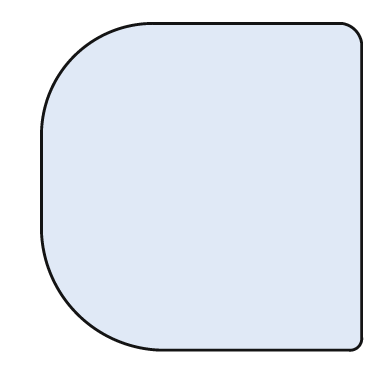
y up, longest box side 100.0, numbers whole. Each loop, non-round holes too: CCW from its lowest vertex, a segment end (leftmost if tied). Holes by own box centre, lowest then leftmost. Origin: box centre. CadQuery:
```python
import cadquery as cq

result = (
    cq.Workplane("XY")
    .moveTo(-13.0, -50.0)
    .lineTo(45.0, -50.0)
    .threePointArc((48.0, -49.0), (49.0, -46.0))
    .lineTo(49.0, 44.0)
    .threePointArc((47.0, 48.0), (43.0, 50.0))
    .lineTo(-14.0, 50.0)
    .threePointArc((-39.0, 40.0), (-49.0, 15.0))
    .lineTo(-49.0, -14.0)
    .threePointArc((-38.0, -39.0), (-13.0, -50.0))
    .close()
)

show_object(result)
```